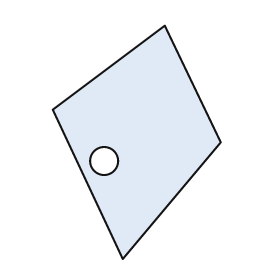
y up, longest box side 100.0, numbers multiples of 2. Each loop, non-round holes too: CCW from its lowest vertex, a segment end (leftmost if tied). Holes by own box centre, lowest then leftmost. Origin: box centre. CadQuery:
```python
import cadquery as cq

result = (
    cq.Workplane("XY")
    .moveTo(-6.0, -50.0)
    .lineTo(36.0, 0.0)
    .lineTo(12.0, 50.0)
    .lineTo(-36.0, 14.0)
    .close()
    .moveTo(-14.0, -8.0)
    .circle(6.0)
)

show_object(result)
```